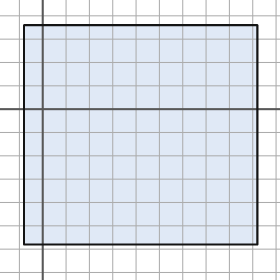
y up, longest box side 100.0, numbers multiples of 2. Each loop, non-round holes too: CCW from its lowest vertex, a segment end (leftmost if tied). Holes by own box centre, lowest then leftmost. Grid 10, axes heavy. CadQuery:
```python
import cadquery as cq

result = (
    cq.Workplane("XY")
    .moveTo(-8.0, -58.0)
    .lineTo(92.0, -58.0)
    .lineTo(92.0, 36.0)
    .lineTo(-8.0, 36.0)
    .close()
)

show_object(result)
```